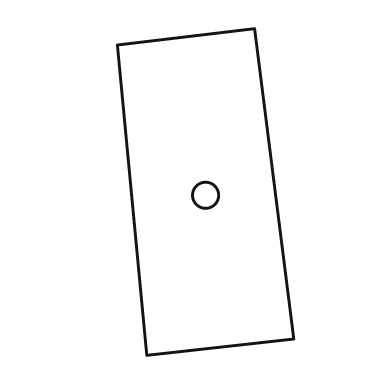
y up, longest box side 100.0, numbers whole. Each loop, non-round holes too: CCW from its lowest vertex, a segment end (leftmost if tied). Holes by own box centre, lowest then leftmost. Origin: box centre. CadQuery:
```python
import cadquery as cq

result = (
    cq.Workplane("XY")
    .moveTo(-18.0, -50.0)
    .lineTo(27.0, -45.0)
    .lineTo(15.0, 50.0)
    .lineTo(-27.0, 45.0)
    .close()
    .moveTo(0.0, -1.0)
    .circle(4.0)
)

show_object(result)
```